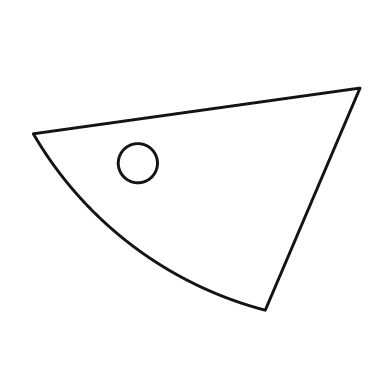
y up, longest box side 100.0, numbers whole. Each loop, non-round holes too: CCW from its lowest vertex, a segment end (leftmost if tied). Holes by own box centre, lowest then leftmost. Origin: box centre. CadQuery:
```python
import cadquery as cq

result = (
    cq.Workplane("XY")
    .moveTo(21.0, -34.0)
    .lineTo(50.0, 34.0)
    .lineTo(-50.0, 20.0)
    .threePointArc((-20.0, -14.0), (21.0, -34.0))
    .close()
    .moveTo(-18.0, 11.0)
    .circle(6.0)
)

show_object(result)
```